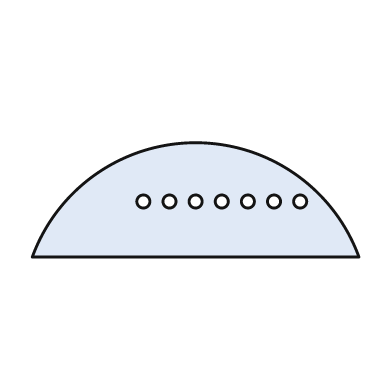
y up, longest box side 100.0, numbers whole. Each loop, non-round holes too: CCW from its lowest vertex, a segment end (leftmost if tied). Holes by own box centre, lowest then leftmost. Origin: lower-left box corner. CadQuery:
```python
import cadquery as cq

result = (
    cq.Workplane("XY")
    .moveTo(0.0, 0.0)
    .lineTo(100.0, 0.0)
    .threePointArc((50.0, 35.0), (0.0, 0.0))
    .close()
    .moveTo(34.0, 17.0)
    .circle(2.0)
    .moveTo(42.0, 17.0)
    .circle(2.0)
    .moveTo(50.0, 17.0)
    .circle(2.0)
    .moveTo(58.0, 17.0)
    .circle(2.0)
    .moveTo(66.0, 17.0)
    .circle(2.0)
    .moveTo(74.0, 17.0)
    .circle(2.0)
    .moveTo(82.0, 17.0)
    .circle(2.0)
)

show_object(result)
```